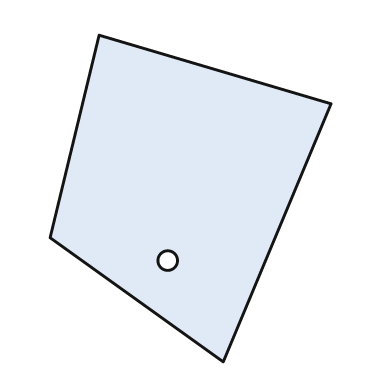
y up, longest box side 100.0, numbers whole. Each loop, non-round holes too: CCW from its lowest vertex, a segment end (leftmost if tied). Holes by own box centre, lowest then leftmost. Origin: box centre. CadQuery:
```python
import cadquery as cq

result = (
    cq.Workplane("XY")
    .moveTo(10.0, -50.0)
    .lineTo(43.0, 29.0)
    .lineTo(-28.0, 50.0)
    .lineTo(-43.0, -12.0)
    .close()
    .moveTo(-7.0, -19.0)
    .circle(3.0)
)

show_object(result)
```